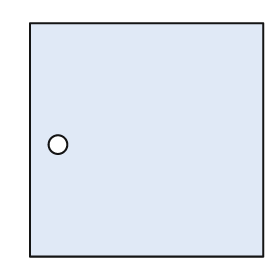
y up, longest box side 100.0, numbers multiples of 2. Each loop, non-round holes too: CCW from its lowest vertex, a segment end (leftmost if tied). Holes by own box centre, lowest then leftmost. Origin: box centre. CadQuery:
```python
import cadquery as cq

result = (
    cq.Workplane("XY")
    .moveTo(-50.0, -50.0)
    .lineTo(50.0, -50.0)
    .lineTo(50.0, 50.0)
    .lineTo(-50.0, 50.0)
    .close()
    .moveTo(-38.0, -2.0)
    .circle(4.0)
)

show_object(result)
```